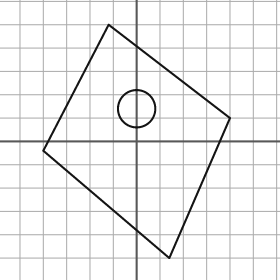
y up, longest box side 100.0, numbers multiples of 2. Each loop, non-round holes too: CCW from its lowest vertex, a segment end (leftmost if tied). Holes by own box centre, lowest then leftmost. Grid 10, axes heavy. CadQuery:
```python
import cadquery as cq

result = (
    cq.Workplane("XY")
    .moveTo(14.0, -50.0)
    .lineTo(40.0, 10.0)
    .lineTo(-12.0, 50.0)
    .lineTo(-40.0, -4.0)
    .close()
    .moveTo(0.0, 14.0)
    .circle(8.0)
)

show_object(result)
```